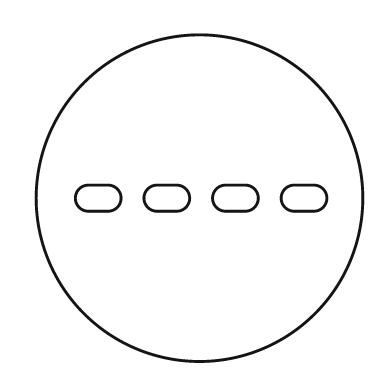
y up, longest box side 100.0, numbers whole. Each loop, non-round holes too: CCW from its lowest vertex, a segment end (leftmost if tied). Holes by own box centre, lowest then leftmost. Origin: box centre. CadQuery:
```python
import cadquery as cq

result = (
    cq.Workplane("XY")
    .moveTo(0.0, 0.0)
    .circle(50.0)
    .moveTo(-34.0, -4.0)
    .lineTo(-28.0, -4.0)
    .threePointArc((-24.0, 0.0), (-28.0, 4.0))
    .lineTo(-34.0, 4.0)
    .threePointArc((-38.0, 0.0), (-34.0, -4.0))
    .close()
    .moveTo(-13.0, -4.0)
    .lineTo(-7.0, -4.0)
    .threePointArc((-3.0, 0.0), (-7.0, 4.0))
    .lineTo(-13.0, 4.0)
    .threePointArc((-17.0, 0.0), (-13.0, -4.0))
    .close()
    .moveTo(8.0, -4.0)
    .lineTo(14.0, -4.0)
    .threePointArc((18.0, 0.0), (14.0, 4.0))
    .lineTo(8.0, 4.0)
    .threePointArc((4.0, 0.0), (8.0, -4.0))
    .close()
    .moveTo(29.0, -4.0)
    .lineTo(35.0, -4.0)
    .threePointArc((39.0, 0.0), (35.0, 4.0))
    .lineTo(29.0, 4.0)
    .threePointArc((25.0, 0.0), (29.0, -4.0))
    .close()
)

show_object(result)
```